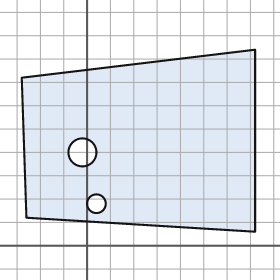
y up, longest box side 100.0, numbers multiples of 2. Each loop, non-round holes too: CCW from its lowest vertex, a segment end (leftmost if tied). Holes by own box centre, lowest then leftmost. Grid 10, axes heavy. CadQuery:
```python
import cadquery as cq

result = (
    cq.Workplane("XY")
    .moveTo(72.0, 6.0)
    .lineTo(72.0, 84.0)
    .lineTo(-28.0, 72.0)
    .lineTo(-26.0, 12.0)
    .close()
    .moveTo(4.0, 18.0)
    .circle(4.0)
    .moveTo(-2.0, 40.0)
    .circle(6.0)
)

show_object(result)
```